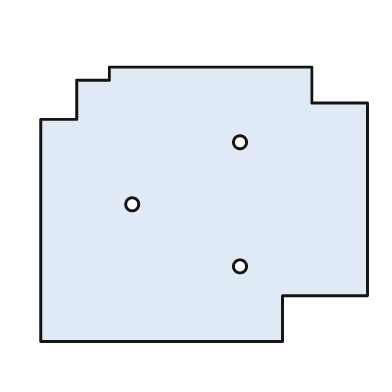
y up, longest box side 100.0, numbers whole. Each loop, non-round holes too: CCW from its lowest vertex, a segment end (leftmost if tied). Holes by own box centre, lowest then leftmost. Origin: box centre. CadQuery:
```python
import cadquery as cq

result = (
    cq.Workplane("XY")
    .moveTo(-50.0, -42.0)
    .lineTo(24.0, -42.0)
    .lineTo(24.0, -28.0)
    .lineTo(50.0, -28.0)
    .lineTo(50.0, 31.0)
    .lineTo(33.0, 31.0)
    .lineTo(33.0, 42.0)
    .lineTo(-29.0, 42.0)
    .lineTo(-29.0, 38.0)
    .lineTo(-39.0, 38.0)
    .lineTo(-39.0, 26.0)
    .lineTo(-50.0, 26.0)
    .close()
    .moveTo(11.0, -19.0)
    .circle(2.0)
    .moveTo(-22.0, 0.0)
    .circle(2.0)
    .moveTo(11.0, 19.0)
    .circle(2.0)
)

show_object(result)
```